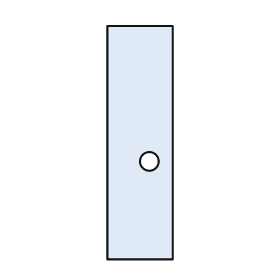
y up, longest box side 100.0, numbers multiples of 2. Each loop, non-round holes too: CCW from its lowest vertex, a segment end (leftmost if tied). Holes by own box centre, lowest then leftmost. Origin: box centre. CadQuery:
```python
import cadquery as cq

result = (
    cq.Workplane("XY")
    .moveTo(-14.0, -50.0)
    .lineTo(14.0, -50.0)
    .lineTo(14.0, 50.0)
    .lineTo(-14.0, 50.0)
    .close()
    .moveTo(4.0, -8.0)
    .circle(4.0)
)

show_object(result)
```